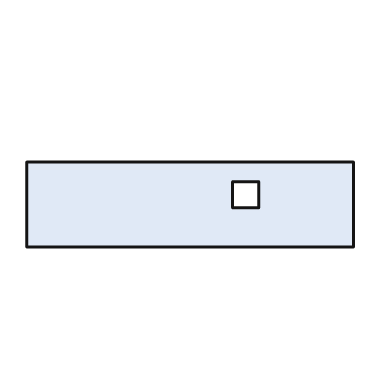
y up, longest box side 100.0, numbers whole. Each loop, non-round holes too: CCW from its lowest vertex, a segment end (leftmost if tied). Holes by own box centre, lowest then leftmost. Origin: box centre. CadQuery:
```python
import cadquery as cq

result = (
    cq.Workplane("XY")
    .moveTo(-50.0, -13.0)
    .lineTo(50.0, -13.0)
    .lineTo(50.0, 13.0)
    .lineTo(-50.0, 13.0)
    .close()
    .moveTo(13.0, -1.0)
    .lineTo(21.0, -1.0)
    .lineTo(21.0, 7.0)
    .lineTo(13.0, 7.0)
    .close()
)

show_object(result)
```